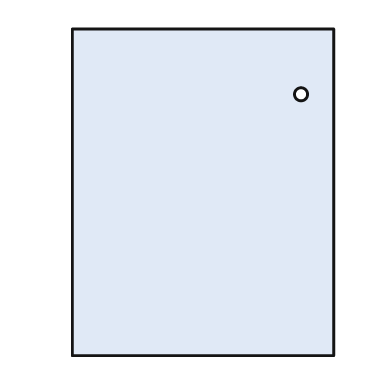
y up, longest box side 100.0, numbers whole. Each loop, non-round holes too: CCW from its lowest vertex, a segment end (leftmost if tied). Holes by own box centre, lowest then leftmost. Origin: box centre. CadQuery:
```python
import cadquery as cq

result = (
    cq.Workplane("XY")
    .moveTo(-40.0, -50.0)
    .lineTo(40.0, -50.0)
    .lineTo(40.0, 50.0)
    .lineTo(-40.0, 50.0)
    .close()
    .moveTo(30.0, 30.0)
    .circle(2.0)
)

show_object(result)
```